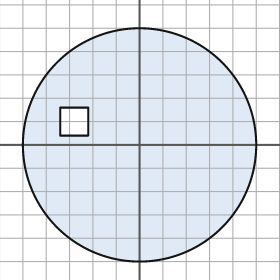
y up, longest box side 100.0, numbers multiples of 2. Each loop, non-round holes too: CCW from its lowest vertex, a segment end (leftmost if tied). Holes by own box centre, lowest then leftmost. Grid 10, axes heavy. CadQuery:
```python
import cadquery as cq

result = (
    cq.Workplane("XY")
    .moveTo(0.0, 0.0)
    .circle(50.0)
    .moveTo(-34.0, 4.0)
    .lineTo(-22.0, 4.0)
    .lineTo(-22.0, 16.0)
    .lineTo(-34.0, 16.0)
    .close()
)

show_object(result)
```